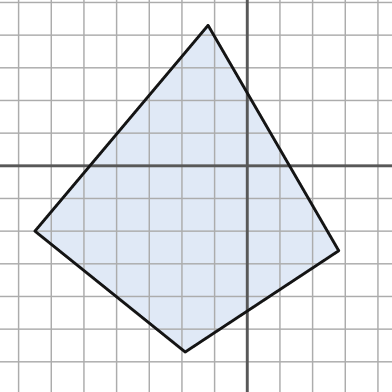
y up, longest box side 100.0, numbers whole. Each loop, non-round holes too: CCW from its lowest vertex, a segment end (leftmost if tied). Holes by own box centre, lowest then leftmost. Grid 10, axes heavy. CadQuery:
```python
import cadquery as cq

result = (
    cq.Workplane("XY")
    .moveTo(-19.0, -57.0)
    .lineTo(28.0, -26.0)
    .lineTo(-12.0, 43.0)
    .lineTo(-65.0, -20.0)
    .close()
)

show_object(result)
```